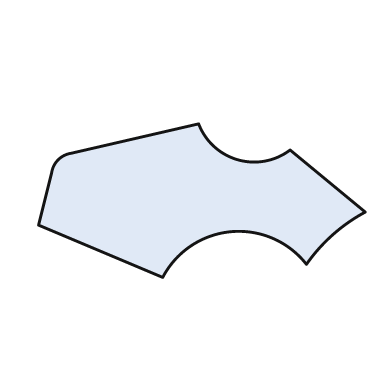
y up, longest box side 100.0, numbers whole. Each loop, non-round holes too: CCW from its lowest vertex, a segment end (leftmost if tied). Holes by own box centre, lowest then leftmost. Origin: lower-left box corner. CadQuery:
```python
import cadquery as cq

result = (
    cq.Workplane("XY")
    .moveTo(38.0, 0.0)
    .threePointArc((59.0, 14.0), (82.0, 4.0))
    .threePointArc((90.0, 13.0), (100.0, 20.0))
    .lineTo(77.0, 39.0)
    .threePointArc((61.0, 36.0), (49.0, 47.0))
    .lineTo(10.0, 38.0)
    .threePointArc((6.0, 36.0), (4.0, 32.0))
    .lineTo(0.0, 16.0)
    .close()
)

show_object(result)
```